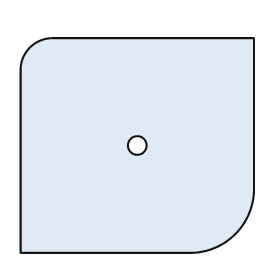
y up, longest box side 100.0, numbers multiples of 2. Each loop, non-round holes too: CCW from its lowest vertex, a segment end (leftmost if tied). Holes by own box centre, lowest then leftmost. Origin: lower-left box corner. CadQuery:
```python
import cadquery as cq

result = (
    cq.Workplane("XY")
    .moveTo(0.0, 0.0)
    .lineTo(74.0, 0.0)
    .threePointArc((92.0, 8.0), (100.0, 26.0))
    .lineTo(100.0, 92.0)
    .lineTo(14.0, 92.0)
    .threePointArc((4.0, 88.0), (0.0, 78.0))
    .close()
    .moveTo(50.0, 46.0)
    .circle(4.0)
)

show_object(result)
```